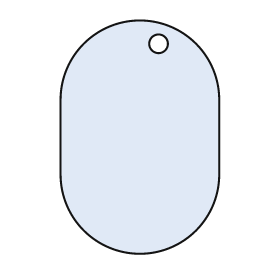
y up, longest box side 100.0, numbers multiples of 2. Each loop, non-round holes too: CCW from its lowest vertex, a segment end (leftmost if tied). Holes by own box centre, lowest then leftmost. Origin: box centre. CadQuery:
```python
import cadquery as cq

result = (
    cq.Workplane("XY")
    .moveTo(-34.0, -16.0)
    .threePointArc((0.0, -50.0), (34.0, -16.0))
    .lineTo(34.0, 16.0)
    .threePointArc((0.0, 50.0), (-34.0, 16.0))
    .close()
    .moveTo(8.0, 40.0)
    .circle(4.0)
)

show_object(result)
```